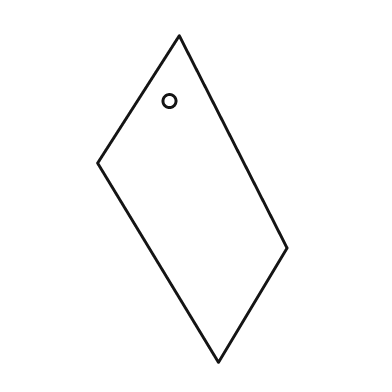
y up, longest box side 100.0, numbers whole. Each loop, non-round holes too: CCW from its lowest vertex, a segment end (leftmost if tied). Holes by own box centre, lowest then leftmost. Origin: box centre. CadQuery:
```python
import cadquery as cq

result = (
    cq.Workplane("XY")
    .moveTo(8.0, -50.0)
    .lineTo(29.0, -15.0)
    .lineTo(-4.0, 50.0)
    .lineTo(-29.0, 11.0)
    .close()
    .moveTo(-7.0, 30.0)
    .circle(2.0)
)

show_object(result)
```